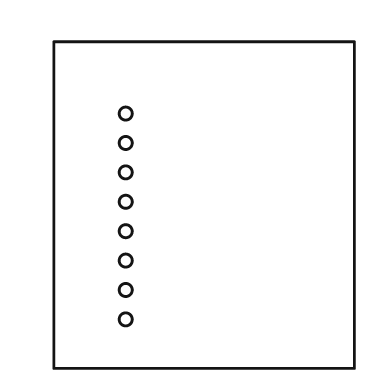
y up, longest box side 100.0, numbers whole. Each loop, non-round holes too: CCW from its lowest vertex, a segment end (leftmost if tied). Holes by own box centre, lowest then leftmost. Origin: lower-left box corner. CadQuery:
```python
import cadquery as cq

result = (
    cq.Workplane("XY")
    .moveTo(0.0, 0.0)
    .lineTo(92.0, 0.0)
    .lineTo(92.0, 100.0)
    .lineTo(0.0, 100.0)
    .close()
    .moveTo(22.0, 15.0)
    .circle(2.0)
    .moveTo(22.0, 24.0)
    .circle(2.0)
    .moveTo(22.0, 33.0)
    .circle(2.0)
    .moveTo(22.0, 42.0)
    .circle(2.0)
    .moveTo(22.0, 51.0)
    .circle(2.0)
    .moveTo(22.0, 60.0)
    .circle(2.0)
    .moveTo(22.0, 69.0)
    .circle(2.0)
    .moveTo(22.0, 78.0)
    .circle(2.0)
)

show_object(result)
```